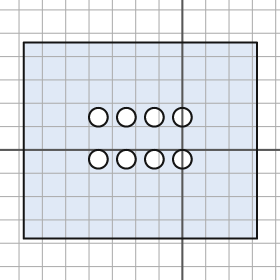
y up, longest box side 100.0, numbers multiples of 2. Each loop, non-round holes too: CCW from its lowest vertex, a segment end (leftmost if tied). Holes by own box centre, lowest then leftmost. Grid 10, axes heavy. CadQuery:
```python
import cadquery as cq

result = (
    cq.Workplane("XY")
    .moveTo(-68.0, -38.0)
    .lineTo(32.0, -38.0)
    .lineTo(32.0, 46.0)
    .lineTo(-68.0, 46.0)
    .close()
    .moveTo(-36.0, -4.0)
    .circle(4.0)
    .moveTo(-24.0, -4.0)
    .circle(4.0)
    .moveTo(-12.0, -4.0)
    .circle(4.0)
    .moveTo(0.0, -4.0)
    .circle(4.0)
    .moveTo(-36.0, 14.0)
    .circle(4.0)
    .moveTo(-24.0, 14.0)
    .circle(4.0)
    .moveTo(-12.0, 14.0)
    .circle(4.0)
    .moveTo(0.0, 14.0)
    .circle(4.0)
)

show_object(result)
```